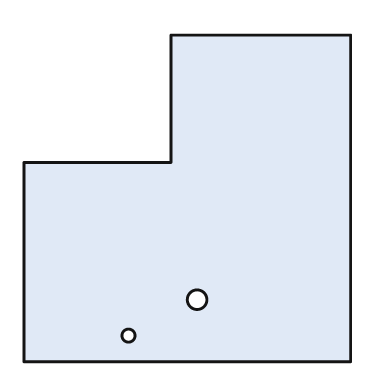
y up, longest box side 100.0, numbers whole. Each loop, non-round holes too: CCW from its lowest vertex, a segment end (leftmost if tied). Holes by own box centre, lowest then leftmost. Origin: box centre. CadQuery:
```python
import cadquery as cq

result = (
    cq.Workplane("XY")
    .moveTo(-50.0, -50.0)
    .lineTo(50.0, -50.0)
    .lineTo(50.0, 50.0)
    .lineTo(-5.0, 50.0)
    .lineTo(-5.0, 11.0)
    .lineTo(-50.0, 11.0)
    .close()
    .moveTo(-18.0, -42.0)
    .circle(2.0)
    .moveTo(3.0, -31.0)
    .circle(3.0)
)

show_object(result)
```